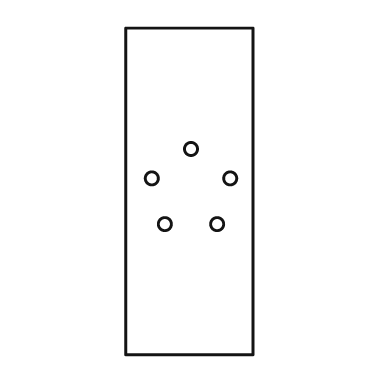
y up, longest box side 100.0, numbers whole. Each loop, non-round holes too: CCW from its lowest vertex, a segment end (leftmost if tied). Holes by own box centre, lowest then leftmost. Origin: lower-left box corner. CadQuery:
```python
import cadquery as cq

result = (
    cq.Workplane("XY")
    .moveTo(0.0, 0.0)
    .lineTo(39.0, 0.0)
    .lineTo(39.0, 100.0)
    .lineTo(0.0, 100.0)
    .close()
    .moveTo(12.0, 40.0)
    .circle(2.0)
    .moveTo(28.0, 40.0)
    .circle(2.0)
    .moveTo(8.0, 54.0)
    .circle(2.0)
    .moveTo(32.0, 54.0)
    .circle(2.0)
    .moveTo(20.0, 63.0)
    .circle(2.0)
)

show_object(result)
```